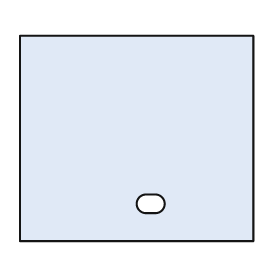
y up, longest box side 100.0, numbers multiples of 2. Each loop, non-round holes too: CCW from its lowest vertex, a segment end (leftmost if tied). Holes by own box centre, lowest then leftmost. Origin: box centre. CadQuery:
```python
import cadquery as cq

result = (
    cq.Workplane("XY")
    .moveTo(-50.0, -44.0)
    .lineTo(50.0, -44.0)
    .lineTo(50.0, 44.0)
    .lineTo(-50.0, 44.0)
    .close()
    .moveTo(4.0, -32.0)
    .lineTo(8.0, -32.0)
    .threePointArc((12.0, -28.0), (8.0, -24.0))
    .lineTo(4.0, -24.0)
    .threePointArc((0.0, -28.0), (4.0, -32.0))
    .close()
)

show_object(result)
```